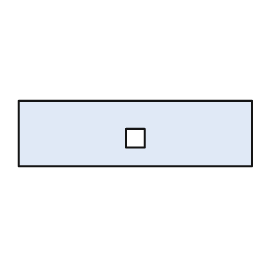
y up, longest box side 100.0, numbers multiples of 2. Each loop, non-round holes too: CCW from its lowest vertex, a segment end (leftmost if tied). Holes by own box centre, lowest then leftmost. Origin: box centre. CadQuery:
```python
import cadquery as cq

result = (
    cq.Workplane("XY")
    .moveTo(-50.0, -14.0)
    .lineTo(50.0, -14.0)
    .lineTo(50.0, 14.0)
    .lineTo(-50.0, 14.0)
    .close()
    .moveTo(-4.0, -6.0)
    .lineTo(4.0, -6.0)
    .lineTo(4.0, 2.0)
    .lineTo(-4.0, 2.0)
    .close()
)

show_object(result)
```